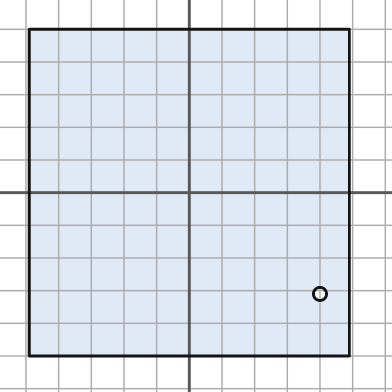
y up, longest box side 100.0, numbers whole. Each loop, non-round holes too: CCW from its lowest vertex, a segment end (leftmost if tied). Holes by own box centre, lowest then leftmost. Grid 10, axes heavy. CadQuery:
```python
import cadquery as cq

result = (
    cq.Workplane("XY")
    .moveTo(-49.0, -50.0)
    .lineTo(49.0, -50.0)
    .lineTo(49.0, 50.0)
    .lineTo(-49.0, 50.0)
    .close()
    .moveTo(40.0, -31.0)
    .circle(2.0)
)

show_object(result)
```